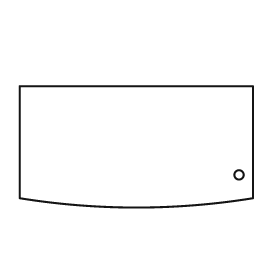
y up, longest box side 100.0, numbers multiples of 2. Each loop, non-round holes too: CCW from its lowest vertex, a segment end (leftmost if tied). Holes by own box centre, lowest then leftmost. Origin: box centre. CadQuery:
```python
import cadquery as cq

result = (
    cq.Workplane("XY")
    .moveTo(-50.0, -22.0)
    .threePointArc((0.0, -26.0), (50.0, -22.0))
    .lineTo(50.0, 26.0)
    .lineTo(-50.0, 26.0)
    .close()
    .moveTo(44.0, -12.0)
    .circle(2.0)
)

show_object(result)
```